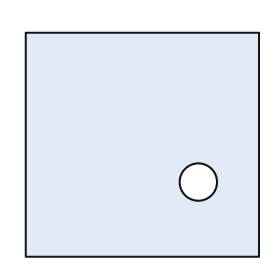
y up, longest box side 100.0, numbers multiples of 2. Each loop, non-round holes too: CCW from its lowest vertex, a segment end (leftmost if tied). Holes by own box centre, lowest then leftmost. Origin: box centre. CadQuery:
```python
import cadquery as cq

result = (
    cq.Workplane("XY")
    .moveTo(-50.0, -48.0)
    .lineTo(50.0, -48.0)
    .lineTo(50.0, 48.0)
    .lineTo(-50.0, 48.0)
    .close()
    .moveTo(24.0, -16.0)
    .circle(8.0)
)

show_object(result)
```